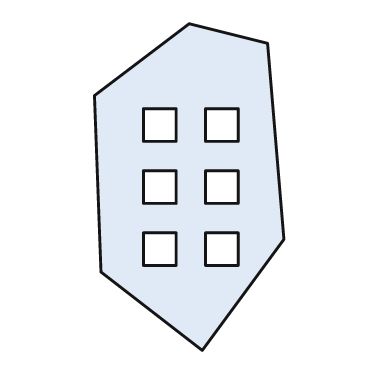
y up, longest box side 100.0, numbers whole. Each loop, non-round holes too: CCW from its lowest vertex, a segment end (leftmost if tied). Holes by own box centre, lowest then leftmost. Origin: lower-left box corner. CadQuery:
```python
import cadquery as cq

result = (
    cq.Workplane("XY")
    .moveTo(33.0, 0.0)
    .lineTo(58.0, 34.0)
    .lineTo(53.0, 94.0)
    .lineTo(29.0, 100.0)
    .lineTo(0.0, 78.0)
    .lineTo(2.0, 24.0)
    .close()
    .moveTo(15.0, 26.0)
    .lineTo(25.0, 26.0)
    .lineTo(25.0, 36.0)
    .lineTo(15.0, 36.0)
    .close()
    .moveTo(34.0, 26.0)
    .lineTo(44.0, 26.0)
    .lineTo(44.0, 36.0)
    .lineTo(34.0, 36.0)
    .close()
    .moveTo(15.0, 45.0)
    .lineTo(25.0, 45.0)
    .lineTo(25.0, 55.0)
    .lineTo(15.0, 55.0)
    .close()
    .moveTo(34.0, 45.0)
    .lineTo(44.0, 45.0)
    .lineTo(44.0, 55.0)
    .lineTo(34.0, 55.0)
    .close()
    .moveTo(15.0, 64.0)
    .lineTo(25.0, 64.0)
    .lineTo(25.0, 74.0)
    .lineTo(15.0, 74.0)
    .close()
    .moveTo(34.0, 64.0)
    .lineTo(44.0, 64.0)
    .lineTo(44.0, 74.0)
    .lineTo(34.0, 74.0)
    .close()
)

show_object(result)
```